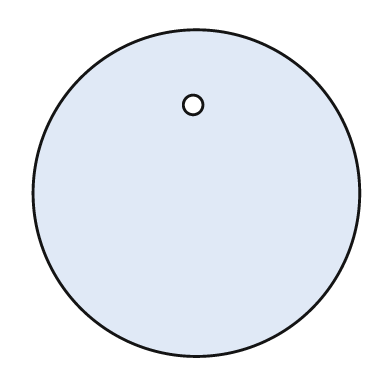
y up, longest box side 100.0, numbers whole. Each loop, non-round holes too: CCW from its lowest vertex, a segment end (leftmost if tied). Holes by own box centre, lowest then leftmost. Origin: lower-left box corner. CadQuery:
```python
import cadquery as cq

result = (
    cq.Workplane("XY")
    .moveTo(50.0, 50.0)
    .circle(50.0)
    .moveTo(49.0, 77.0)
    .circle(3.0)
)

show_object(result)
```